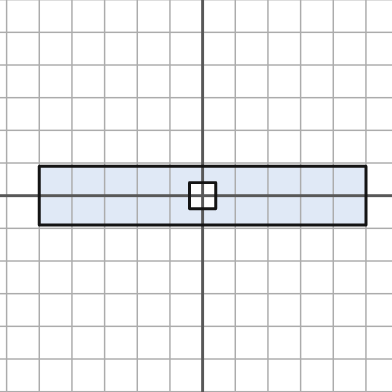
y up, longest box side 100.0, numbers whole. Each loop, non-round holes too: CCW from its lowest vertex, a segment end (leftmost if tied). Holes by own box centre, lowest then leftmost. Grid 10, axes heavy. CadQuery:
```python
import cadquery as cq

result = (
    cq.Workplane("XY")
    .moveTo(-50.0, -9.0)
    .lineTo(50.0, -9.0)
    .lineTo(50.0, 9.0)
    .lineTo(-50.0, 9.0)
    .close()
    .moveTo(-4.0, -4.0)
    .lineTo(4.0, -4.0)
    .lineTo(4.0, 4.0)
    .lineTo(-4.0, 4.0)
    .close()
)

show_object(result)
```